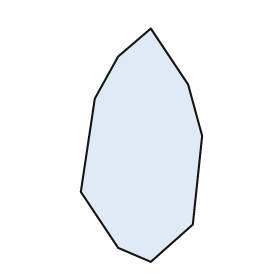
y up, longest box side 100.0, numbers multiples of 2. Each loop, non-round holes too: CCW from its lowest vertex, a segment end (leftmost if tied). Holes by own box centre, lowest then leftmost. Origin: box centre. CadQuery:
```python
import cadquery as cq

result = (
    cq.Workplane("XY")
    .moveTo(4.0, -50.0)
    .lineTo(22.0, -34.0)
    .lineTo(26.0, 4.0)
    .lineTo(20.0, 26.0)
    .lineTo(4.0, 50.0)
    .lineTo(-10.0, 38.0)
    .lineTo(-20.0, 20.0)
    .lineTo(-26.0, -20.0)
    .lineTo(-10.0, -44.0)
    .close()
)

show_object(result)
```